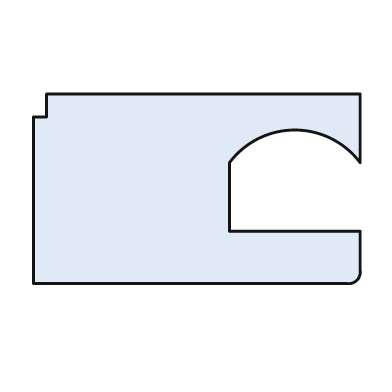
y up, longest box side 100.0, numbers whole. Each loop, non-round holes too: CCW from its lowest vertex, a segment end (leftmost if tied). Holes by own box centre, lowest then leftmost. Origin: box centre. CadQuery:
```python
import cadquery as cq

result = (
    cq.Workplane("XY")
    .moveTo(-50.0, -29.0)
    .lineTo(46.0, -29.0)
    .threePointArc((49.0, -28.0), (50.0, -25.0))
    .lineTo(50.0, -13.0)
    .lineTo(10.0, -13.0)
    .lineTo(10.0, 8.0)
    .threePointArc((30.0, 18.0), (50.0, 8.0))
    .lineTo(50.0, 29.0)
    .lineTo(-46.0, 29.0)
    .lineTo(-46.0, 22.0)
    .lineTo(-50.0, 22.0)
    .close()
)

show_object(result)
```